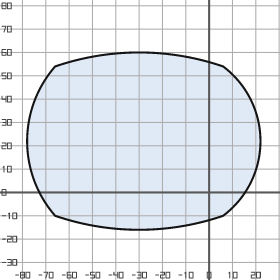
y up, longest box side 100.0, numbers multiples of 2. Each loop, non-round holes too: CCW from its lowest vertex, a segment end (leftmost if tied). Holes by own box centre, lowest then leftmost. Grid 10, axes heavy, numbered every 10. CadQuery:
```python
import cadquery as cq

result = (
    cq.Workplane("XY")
    .moveTo(-66.0, -10.0)
    .threePointArc((-30.0, -16.0), (6.0, -10.0))
    .threePointArc((22.0, 22.0), (6.0, 54.0))
    .threePointArc((-30.0, 60.0), (-66.0, 54.0))
    .threePointArc((-78.0, 22.0), (-66.0, -10.0))
    .close()
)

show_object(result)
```